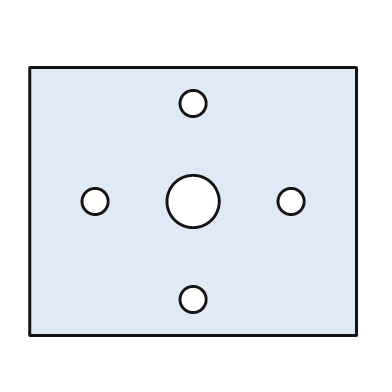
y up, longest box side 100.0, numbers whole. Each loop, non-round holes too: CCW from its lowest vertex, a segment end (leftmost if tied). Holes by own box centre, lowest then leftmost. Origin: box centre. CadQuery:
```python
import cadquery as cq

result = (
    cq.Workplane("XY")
    .moveTo(-50.0, -41.0)
    .lineTo(50.0, -41.0)
    .lineTo(50.0, 41.0)
    .lineTo(-50.0, 41.0)
    .close()
    .moveTo(0.0, -30.0)
    .circle(4.0)
    .moveTo(-30.0, 0.0)
    .circle(4.0)
    .moveTo(0.0, 0.0)
    .circle(8.0)
    .moveTo(30.0, 0.0)
    .circle(4.0)
    .moveTo(0.0, 30.0)
    .circle(4.0)
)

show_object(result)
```